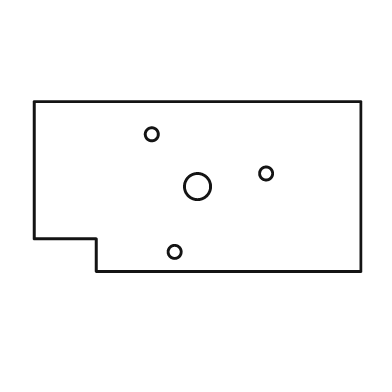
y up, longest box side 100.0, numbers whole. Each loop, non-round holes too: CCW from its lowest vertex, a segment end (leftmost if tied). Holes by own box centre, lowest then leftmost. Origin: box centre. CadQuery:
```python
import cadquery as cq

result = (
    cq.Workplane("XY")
    .moveTo(-31.0, -26.0)
    .lineTo(50.0, -26.0)
    .lineTo(50.0, 26.0)
    .lineTo(-50.0, 26.0)
    .lineTo(-50.0, -16.0)
    .lineTo(-31.0, -16.0)
    .close()
    .moveTo(-7.0, -20.0)
    .circle(2.0)
    .moveTo(0.0, 0.0)
    .circle(4.0)
    .moveTo(21.0, 4.0)
    .circle(2.0)
    .moveTo(-14.0, 16.0)
    .circle(2.0)
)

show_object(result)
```